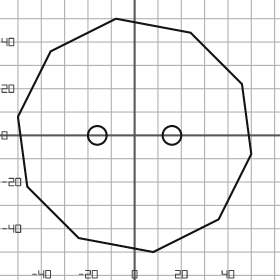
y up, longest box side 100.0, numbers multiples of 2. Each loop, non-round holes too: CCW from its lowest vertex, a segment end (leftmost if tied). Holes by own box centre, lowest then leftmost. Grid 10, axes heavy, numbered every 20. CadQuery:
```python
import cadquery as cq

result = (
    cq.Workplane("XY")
    .moveTo(8.0, -50.0)
    .lineTo(36.0, -36.0)
    .lineTo(50.0, -8.0)
    .lineTo(46.0, 22.0)
    .lineTo(24.0, 44.0)
    .lineTo(-8.0, 50.0)
    .lineTo(-36.0, 36.0)
    .lineTo(-50.0, 8.0)
    .lineTo(-46.0, -22.0)
    .lineTo(-24.0, -44.0)
    .close()
    .moveTo(-16.0, 0.0)
    .circle(4.0)
    .moveTo(16.0, 0.0)
    .circle(4.0)
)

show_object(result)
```